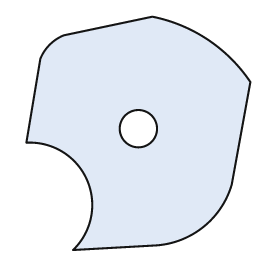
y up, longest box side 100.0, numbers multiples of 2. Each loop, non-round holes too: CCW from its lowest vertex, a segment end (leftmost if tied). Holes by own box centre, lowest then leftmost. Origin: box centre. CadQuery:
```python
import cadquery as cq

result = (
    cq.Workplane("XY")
    .moveTo(-28.0, -50.0)
    .lineTo(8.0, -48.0)
    .threePointArc((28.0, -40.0), (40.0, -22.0))
    .lineTo(48.0, 22.0)
    .threePointArc((30.0, 40.0), (6.0, 50.0))
    .lineTo(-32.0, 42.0)
    .threePointArc((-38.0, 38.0), (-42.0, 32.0))
    .lineTo(-48.0, -4.0)
    .threePointArc((-22.0, -20.0), (-28.0, -50.0))
    .close()
    .moveTo(0.0, 2.0)
    .circle(8.0)
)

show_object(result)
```